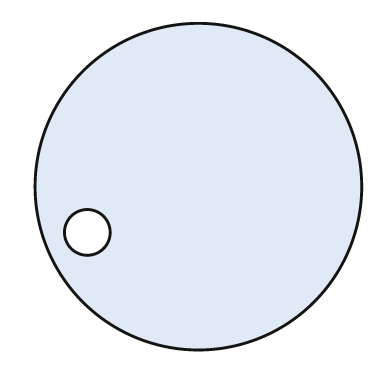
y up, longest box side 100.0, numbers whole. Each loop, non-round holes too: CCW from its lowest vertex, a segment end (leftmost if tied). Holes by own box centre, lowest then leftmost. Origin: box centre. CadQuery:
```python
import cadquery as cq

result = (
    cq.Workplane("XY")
    .moveTo(0.0, 0.0)
    .circle(50.0)
    .moveTo(-34.0, -14.0)
    .circle(7.0)
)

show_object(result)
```